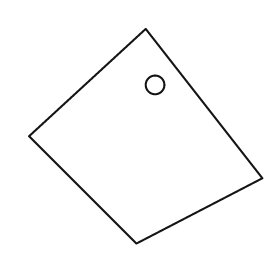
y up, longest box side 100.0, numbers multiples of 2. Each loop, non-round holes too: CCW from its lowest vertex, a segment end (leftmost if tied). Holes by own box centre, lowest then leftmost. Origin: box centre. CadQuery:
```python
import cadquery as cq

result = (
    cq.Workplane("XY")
    .moveTo(-4.0, -46.0)
    .lineTo(50.0, -18.0)
    .lineTo(0.0, 46.0)
    .lineTo(-50.0, 0.0)
    .close()
    .moveTo(4.0, 22.0)
    .circle(4.0)
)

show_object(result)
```